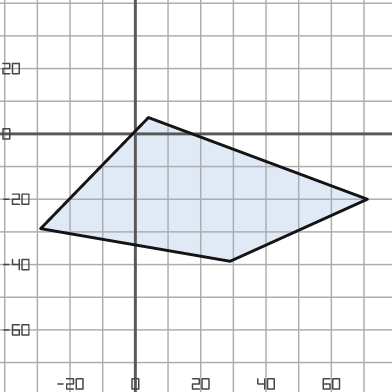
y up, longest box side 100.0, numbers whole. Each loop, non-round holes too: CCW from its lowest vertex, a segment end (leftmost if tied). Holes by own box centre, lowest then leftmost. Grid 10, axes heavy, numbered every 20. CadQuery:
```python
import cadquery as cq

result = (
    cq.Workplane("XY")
    .moveTo(29.0, -39.0)
    .lineTo(71.0, -20.0)
    .lineTo(4.0, 5.0)
    .lineTo(-29.0, -29.0)
    .close()
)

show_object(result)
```